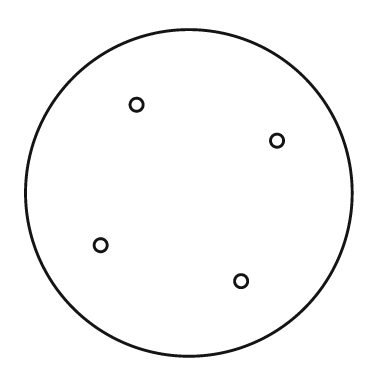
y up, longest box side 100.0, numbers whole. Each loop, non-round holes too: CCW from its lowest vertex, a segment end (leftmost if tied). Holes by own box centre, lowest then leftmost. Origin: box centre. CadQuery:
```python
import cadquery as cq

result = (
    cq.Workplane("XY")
    .moveTo(0.0, 0.0)
    .circle(50.0)
    .moveTo(16.0, -27.0)
    .circle(2.0)
    .moveTo(-27.0, -16.0)
    .circle(2.0)
    .moveTo(27.0, 16.0)
    .circle(2.0)
    .moveTo(-16.0, 27.0)
    .circle(2.0)
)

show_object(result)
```